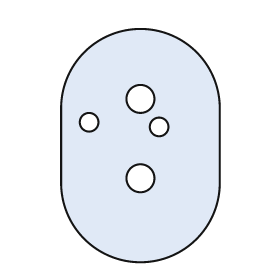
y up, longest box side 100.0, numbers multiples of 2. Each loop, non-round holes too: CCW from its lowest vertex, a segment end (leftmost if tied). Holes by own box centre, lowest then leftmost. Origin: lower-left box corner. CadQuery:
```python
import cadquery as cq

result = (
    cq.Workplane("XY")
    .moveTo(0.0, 34.0)
    .threePointArc((34.0, 0.0), (68.0, 34.0))
    .lineTo(68.0, 66.0)
    .threePointArc((34.0, 100.0), (0.0, 66.0))
    .close()
    .moveTo(34.0, 36.0)
    .circle(6.0)
    .moveTo(42.0, 58.0)
    .circle(4.0)
    .moveTo(12.0, 60.0)
    .circle(4.0)
    .moveTo(34.0, 70.0)
    .circle(6.0)
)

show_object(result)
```